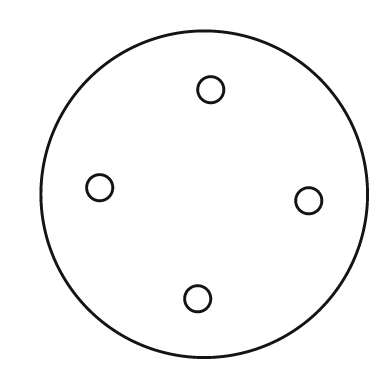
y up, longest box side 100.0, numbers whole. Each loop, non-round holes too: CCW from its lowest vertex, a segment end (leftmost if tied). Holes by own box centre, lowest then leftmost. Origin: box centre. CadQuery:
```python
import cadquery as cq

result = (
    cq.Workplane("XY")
    .moveTo(0.0, 0.0)
    .circle(50.0)
    .moveTo(-2.0, -32.0)
    .circle(4.0)
    .moveTo(32.0, -2.0)
    .circle(4.0)
    .moveTo(-32.0, 2.0)
    .circle(4.0)
    .moveTo(2.0, 32.0)
    .circle(4.0)
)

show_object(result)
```